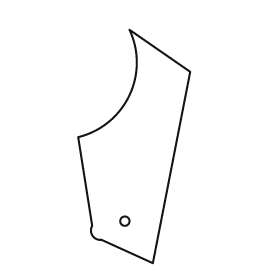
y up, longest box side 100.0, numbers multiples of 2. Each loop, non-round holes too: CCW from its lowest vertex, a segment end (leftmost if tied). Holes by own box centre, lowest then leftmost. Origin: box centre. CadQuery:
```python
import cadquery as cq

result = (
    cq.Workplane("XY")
    .moveTo(8.0, -50.0)
    .lineTo(24.0, 32.0)
    .lineTo(-2.0, 50.0)
    .threePointArc((-2.0, 22.0), (-24.0, 4.0))
    .lineTo(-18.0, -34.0)
    .threePointArc((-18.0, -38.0), (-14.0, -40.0))
    .close()
    .moveTo(-4.0, -32.0)
    .circle(2.0)
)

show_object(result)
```